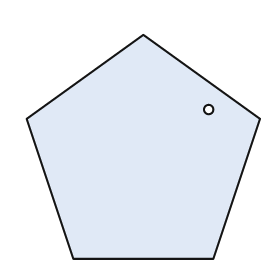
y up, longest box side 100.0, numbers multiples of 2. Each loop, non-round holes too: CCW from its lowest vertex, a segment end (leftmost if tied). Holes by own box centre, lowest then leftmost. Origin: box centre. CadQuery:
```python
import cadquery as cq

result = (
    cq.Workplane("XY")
    .moveTo(-30.0, -48.0)
    .lineTo(30.0, -48.0)
    .lineTo(50.0, 12.0)
    .lineTo(0.0, 48.0)
    .lineTo(-50.0, 12.0)
    .close()
    .moveTo(28.0, 16.0)
    .circle(2.0)
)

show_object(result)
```